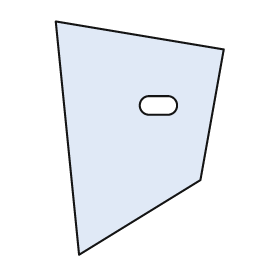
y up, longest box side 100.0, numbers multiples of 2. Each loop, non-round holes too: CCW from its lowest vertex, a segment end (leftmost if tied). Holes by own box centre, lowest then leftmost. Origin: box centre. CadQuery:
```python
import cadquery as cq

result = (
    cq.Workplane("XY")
    .moveTo(-26.0, -50.0)
    .lineTo(26.0, -18.0)
    .lineTo(36.0, 38.0)
    .lineTo(-36.0, 50.0)
    .close()
    .moveTo(4.0, 10.0)
    .lineTo(12.0, 10.0)
    .threePointArc((16.0, 14.0), (12.0, 18.0))
    .lineTo(4.0, 18.0)
    .threePointArc((0.0, 14.0), (4.0, 10.0))
    .close()
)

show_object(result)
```